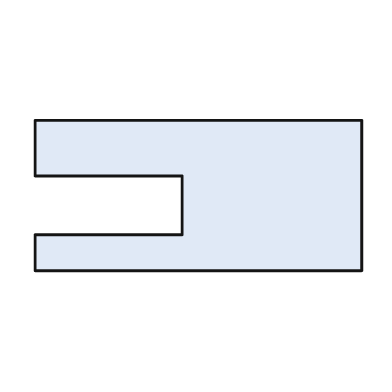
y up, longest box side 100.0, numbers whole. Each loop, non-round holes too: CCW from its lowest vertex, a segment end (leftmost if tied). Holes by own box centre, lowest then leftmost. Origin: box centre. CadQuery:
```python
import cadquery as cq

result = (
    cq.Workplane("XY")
    .moveTo(-50.0, -23.0)
    .lineTo(50.0, -23.0)
    .lineTo(50.0, 23.0)
    .lineTo(-50.0, 23.0)
    .lineTo(-50.0, 6.0)
    .lineTo(-5.0, 6.0)
    .lineTo(-5.0, -12.0)
    .lineTo(-50.0, -12.0)
    .close()
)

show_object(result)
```